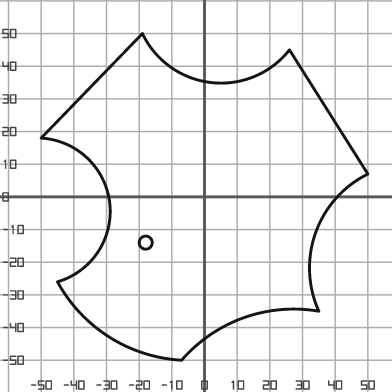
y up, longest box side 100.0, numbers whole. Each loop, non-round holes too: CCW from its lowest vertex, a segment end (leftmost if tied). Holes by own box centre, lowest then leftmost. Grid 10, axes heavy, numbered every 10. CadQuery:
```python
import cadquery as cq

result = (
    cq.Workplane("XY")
    .moveTo(-7.0, -50.0)
    .threePointArc((12.0, -37.0), (35.0, -35.0))
    .threePointArc((34.0, -11.0), (50.0, 7.0))
    .lineTo(26.0, 45.0)
    .threePointArc((2.0, 35.0), (-19.0, 50.0))
    .lineTo(-50.0, 18.0)
    .threePointArc((-29.0, -2.0), (-45.0, -26.0))
    .threePointArc((-29.0, -43.0), (-7.0, -50.0))
    .close()
    .moveTo(-18.0, -14.0)
    .circle(2.0)
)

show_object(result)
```